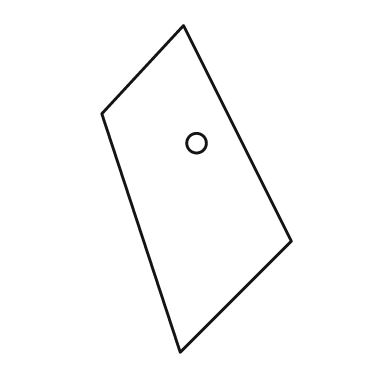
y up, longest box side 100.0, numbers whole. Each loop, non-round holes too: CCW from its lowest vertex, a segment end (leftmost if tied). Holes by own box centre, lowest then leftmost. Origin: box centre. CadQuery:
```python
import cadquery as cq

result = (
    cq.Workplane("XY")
    .moveTo(-5.0, -50.0)
    .lineTo(29.0, -16.0)
    .lineTo(-4.0, 50.0)
    .lineTo(-29.0, 23.0)
    .close()
    .moveTo(0.0, 14.0)
    .circle(3.0)
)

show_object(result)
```